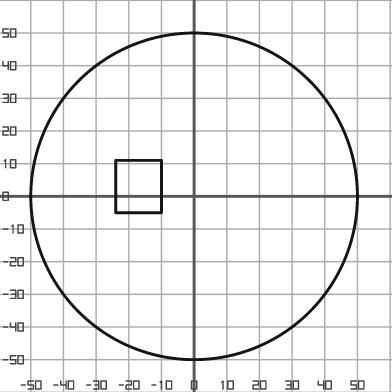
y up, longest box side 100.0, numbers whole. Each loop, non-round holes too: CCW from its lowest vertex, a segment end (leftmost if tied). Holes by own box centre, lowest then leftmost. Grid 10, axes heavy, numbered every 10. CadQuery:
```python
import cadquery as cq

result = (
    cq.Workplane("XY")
    .moveTo(0.0, 0.0)
    .circle(50.0)
    .moveTo(-24.0, -5.0)
    .lineTo(-10.0, -5.0)
    .lineTo(-10.0, 11.0)
    .lineTo(-24.0, 11.0)
    .close()
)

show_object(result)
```